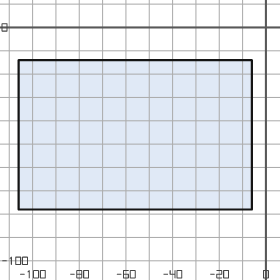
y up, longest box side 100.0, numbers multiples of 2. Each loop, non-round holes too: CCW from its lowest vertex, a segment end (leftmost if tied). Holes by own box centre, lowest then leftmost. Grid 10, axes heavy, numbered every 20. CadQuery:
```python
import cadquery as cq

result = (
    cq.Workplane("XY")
    .moveTo(-106.0, -78.0)
    .lineTo(-6.0, -78.0)
    .lineTo(-6.0, -14.0)
    .lineTo(-106.0, -14.0)
    .close()
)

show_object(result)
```